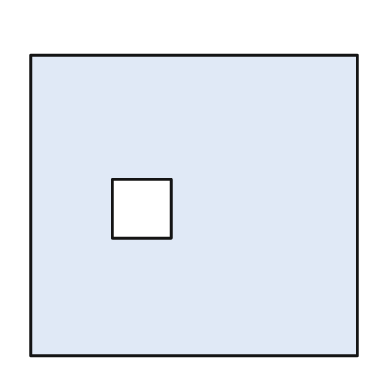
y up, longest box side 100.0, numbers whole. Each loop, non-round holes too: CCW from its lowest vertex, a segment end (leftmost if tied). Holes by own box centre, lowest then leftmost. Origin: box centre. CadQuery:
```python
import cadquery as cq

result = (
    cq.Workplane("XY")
    .moveTo(-50.0, -46.0)
    .lineTo(50.0, -46.0)
    .lineTo(50.0, 46.0)
    .lineTo(-50.0, 46.0)
    .close()
    .moveTo(-25.0, -10.0)
    .lineTo(-7.0, -10.0)
    .lineTo(-7.0, 8.0)
    .lineTo(-25.0, 8.0)
    .close()
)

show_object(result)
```